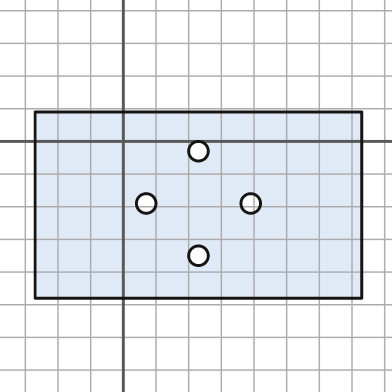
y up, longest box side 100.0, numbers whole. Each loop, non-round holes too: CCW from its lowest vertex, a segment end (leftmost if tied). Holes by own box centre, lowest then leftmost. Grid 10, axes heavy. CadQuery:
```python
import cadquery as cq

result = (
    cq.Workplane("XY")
    .moveTo(-27.0, -48.0)
    .lineTo(73.0, -48.0)
    .lineTo(73.0, 9.0)
    .lineTo(-27.0, 9.0)
    .close()
    .moveTo(23.0, -35.0)
    .circle(3.0)
    .moveTo(7.0, -19.0)
    .circle(3.0)
    .moveTo(39.0, -19.0)
    .circle(3.0)
    .moveTo(23.0, -3.0)
    .circle(3.0)
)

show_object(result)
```